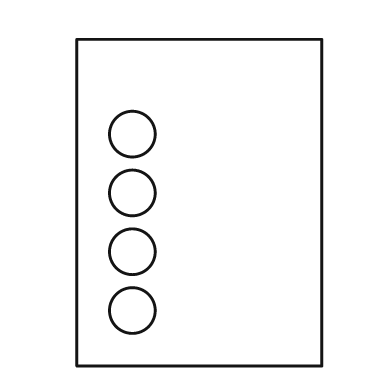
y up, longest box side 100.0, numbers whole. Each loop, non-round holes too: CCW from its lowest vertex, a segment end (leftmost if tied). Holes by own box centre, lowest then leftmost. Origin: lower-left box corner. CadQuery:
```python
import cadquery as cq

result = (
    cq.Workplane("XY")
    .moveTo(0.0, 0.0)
    .lineTo(75.0, 0.0)
    .lineTo(75.0, 100.0)
    .lineTo(0.0, 100.0)
    .close()
    .moveTo(17.0, 17.0)
    .circle(7.0)
    .moveTo(17.0, 35.0)
    .circle(7.0)
    .moveTo(17.0, 53.0)
    .circle(7.0)
    .moveTo(17.0, 71.0)
    .circle(7.0)
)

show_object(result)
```